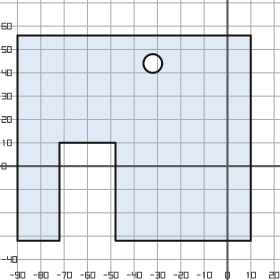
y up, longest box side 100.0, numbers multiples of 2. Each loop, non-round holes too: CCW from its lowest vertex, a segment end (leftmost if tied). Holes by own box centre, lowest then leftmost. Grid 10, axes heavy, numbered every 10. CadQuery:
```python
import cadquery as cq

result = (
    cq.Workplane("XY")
    .moveTo(-90.0, -32.0)
    .lineTo(-72.0, -32.0)
    .lineTo(-72.0, 10.0)
    .lineTo(-48.0, 10.0)
    .lineTo(-48.0, -32.0)
    .lineTo(10.0, -32.0)
    .lineTo(10.0, 56.0)
    .lineTo(-90.0, 56.0)
    .close()
    .moveTo(-32.0, 44.0)
    .circle(4.0)
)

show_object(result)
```